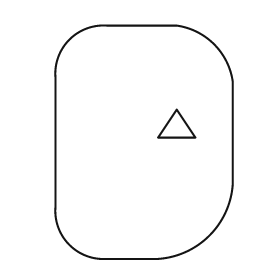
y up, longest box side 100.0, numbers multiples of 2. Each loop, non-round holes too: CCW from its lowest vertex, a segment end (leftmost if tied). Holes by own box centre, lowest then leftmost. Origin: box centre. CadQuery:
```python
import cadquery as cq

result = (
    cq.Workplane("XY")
    .moveTo(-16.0, -50.0)
    .lineTo(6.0, -50.0)
    .threePointArc((28.0, -40.0), (38.0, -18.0))
    .lineTo(38.0, 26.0)
    .threePointArc((30.0, 42.0), (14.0, 50.0))
    .lineTo(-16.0, 50.0)
    .threePointArc((-32.0, 44.0), (-38.0, 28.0))
    .lineTo(-38.0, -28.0)
    .threePointArc((-32.0, -44.0), (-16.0, -50.0))
    .close()
    .moveTo(6.0, 2.0)
    .lineTo(22.0, 2.0)
    .lineTo(14.0, 14.0)
    .close()
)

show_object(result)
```